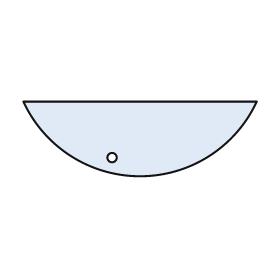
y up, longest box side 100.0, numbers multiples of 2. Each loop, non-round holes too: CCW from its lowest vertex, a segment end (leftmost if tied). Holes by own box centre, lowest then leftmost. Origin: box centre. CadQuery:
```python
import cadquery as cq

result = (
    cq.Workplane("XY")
    .moveTo(-50.0, 16.0)
    .threePointArc((0.0, -16.0), (50.0, 16.0))
    .close()
    .moveTo(-12.0, -8.0)
    .circle(2.0)
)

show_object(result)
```